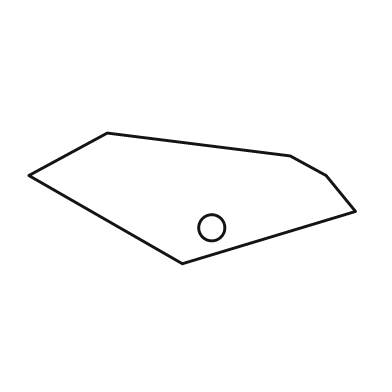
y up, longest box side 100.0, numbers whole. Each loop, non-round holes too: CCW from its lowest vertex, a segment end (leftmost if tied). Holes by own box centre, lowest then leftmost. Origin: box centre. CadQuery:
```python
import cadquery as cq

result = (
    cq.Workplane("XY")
    .moveTo(-3.0, -20.0)
    .lineTo(50.0, -4.0)
    .lineTo(41.0, 7.0)
    .lineTo(30.0, 13.0)
    .lineTo(-26.0, 20.0)
    .lineTo(-50.0, 7.0)
    .close()
    .moveTo(6.0, -9.0)
    .circle(4.0)
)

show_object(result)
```